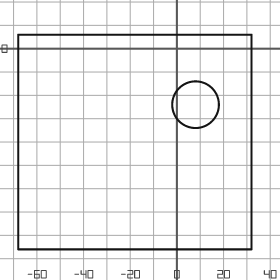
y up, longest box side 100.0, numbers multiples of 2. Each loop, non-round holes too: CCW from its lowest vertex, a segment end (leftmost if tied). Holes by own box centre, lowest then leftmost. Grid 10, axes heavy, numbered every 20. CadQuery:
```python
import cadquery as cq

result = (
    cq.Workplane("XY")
    .moveTo(-68.0, -86.0)
    .lineTo(32.0, -86.0)
    .lineTo(32.0, 6.0)
    .lineTo(-68.0, 6.0)
    .close()
    .moveTo(8.0, -24.0)
    .circle(10.0)
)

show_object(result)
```